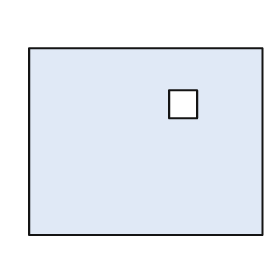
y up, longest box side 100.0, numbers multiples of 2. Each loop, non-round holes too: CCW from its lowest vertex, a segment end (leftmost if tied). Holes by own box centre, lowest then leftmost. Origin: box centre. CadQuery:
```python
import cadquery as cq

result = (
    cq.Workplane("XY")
    .moveTo(-50.0, -40.0)
    .lineTo(50.0, -40.0)
    .lineTo(50.0, 40.0)
    .lineTo(-50.0, 40.0)
    .close()
    .moveTo(10.0, 10.0)
    .lineTo(22.0, 10.0)
    .lineTo(22.0, 22.0)
    .lineTo(10.0, 22.0)
    .close()
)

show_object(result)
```